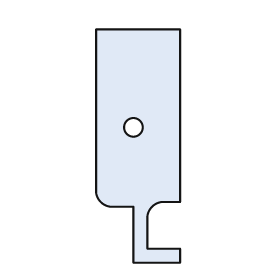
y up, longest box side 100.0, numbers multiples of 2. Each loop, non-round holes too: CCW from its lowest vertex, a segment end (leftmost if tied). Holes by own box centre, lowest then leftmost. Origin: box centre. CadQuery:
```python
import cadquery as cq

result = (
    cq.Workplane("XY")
    .moveTo(-2.0, -50.0)
    .lineTo(18.0, -50.0)
    .lineTo(18.0, -44.0)
    .lineTo(4.0, -44.0)
    .lineTo(4.0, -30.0)
    .threePointArc((6.0, -26.0), (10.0, -24.0))
    .lineTo(18.0, -24.0)
    .lineTo(18.0, 50.0)
    .lineTo(-18.0, 50.0)
    .lineTo(-18.0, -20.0)
    .threePointArc((-16.0, -24.0), (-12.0, -26.0))
    .lineTo(-2.0, -26.0)
    .close()
    .moveTo(-2.0, 8.0)
    .circle(4.0)
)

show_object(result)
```